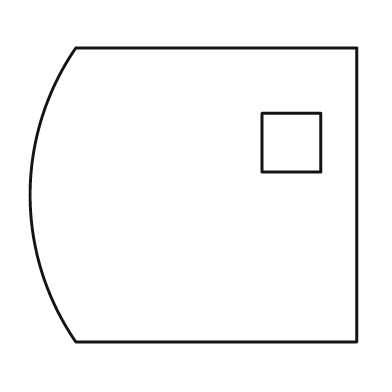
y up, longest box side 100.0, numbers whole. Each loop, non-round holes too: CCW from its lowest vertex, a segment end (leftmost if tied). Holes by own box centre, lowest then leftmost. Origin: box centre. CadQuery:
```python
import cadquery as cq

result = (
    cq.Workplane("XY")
    .moveTo(-36.0, -45.0)
    .lineTo(50.0, -45.0)
    .lineTo(50.0, 45.0)
    .lineTo(-36.0, 45.0)
    .threePointArc((-50.0, 0.0), (-36.0, -45.0))
    .close()
    .moveTo(21.0, 7.0)
    .lineTo(39.0, 7.0)
    .lineTo(39.0, 25.0)
    .lineTo(21.0, 25.0)
    .close()
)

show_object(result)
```